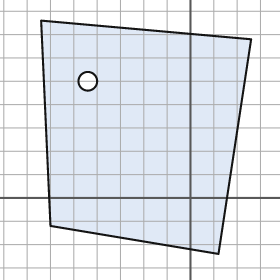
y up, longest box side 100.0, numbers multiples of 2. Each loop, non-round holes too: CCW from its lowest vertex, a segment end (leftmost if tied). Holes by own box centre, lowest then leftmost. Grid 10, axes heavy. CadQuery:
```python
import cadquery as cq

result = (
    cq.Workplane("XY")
    .moveTo(12.0, -24.0)
    .lineTo(26.0, 68.0)
    .lineTo(-64.0, 76.0)
    .lineTo(-60.0, -12.0)
    .close()
    .moveTo(-44.0, 50.0)
    .circle(4.0)
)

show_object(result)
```